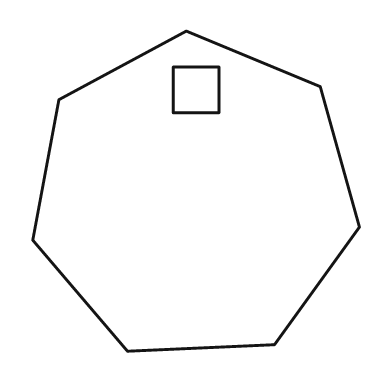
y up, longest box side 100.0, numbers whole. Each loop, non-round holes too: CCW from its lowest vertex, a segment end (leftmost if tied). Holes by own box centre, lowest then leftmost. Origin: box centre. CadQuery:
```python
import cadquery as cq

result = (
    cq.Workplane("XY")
    .moveTo(-21.0, -49.0)
    .lineTo(24.0, -47.0)
    .lineTo(50.0, -11.0)
    .lineTo(38.0, 32.0)
    .lineTo(-3.0, 49.0)
    .lineTo(-42.0, 28.0)
    .lineTo(-50.0, -15.0)
    .close()
    .moveTo(-7.0, 24.0)
    .lineTo(7.0, 24.0)
    .lineTo(7.0, 38.0)
    .lineTo(-7.0, 38.0)
    .close()
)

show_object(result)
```